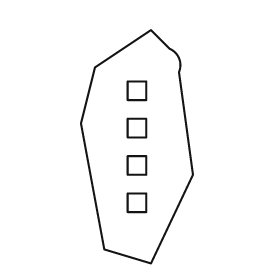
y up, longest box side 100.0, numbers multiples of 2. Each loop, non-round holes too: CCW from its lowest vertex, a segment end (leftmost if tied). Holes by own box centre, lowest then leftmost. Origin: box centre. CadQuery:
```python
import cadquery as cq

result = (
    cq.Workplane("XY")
    .moveTo(6.0, -50.0)
    .lineTo(24.0, -12.0)
    .lineTo(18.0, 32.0)
    .threePointArc((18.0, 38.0), (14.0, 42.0))
    .lineTo(6.0, 50.0)
    .lineTo(-18.0, 34.0)
    .lineTo(-24.0, 10.0)
    .lineTo(-14.0, -44.0)
    .close()
    .moveTo(-4.0, -28.0)
    .lineTo(4.0, -28.0)
    .lineTo(4.0, -20.0)
    .lineTo(-4.0, -20.0)
    .close()
    .moveTo(-4.0, -12.0)
    .lineTo(4.0, -12.0)
    .lineTo(4.0, -4.0)
    .lineTo(-4.0, -4.0)
    .close()
    .moveTo(-4.0, 4.0)
    .lineTo(4.0, 4.0)
    .lineTo(4.0, 12.0)
    .lineTo(-4.0, 12.0)
    .close()
    .moveTo(-4.0, 20.0)
    .lineTo(4.0, 20.0)
    .lineTo(4.0, 28.0)
    .lineTo(-4.0, 28.0)
    .close()
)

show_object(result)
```